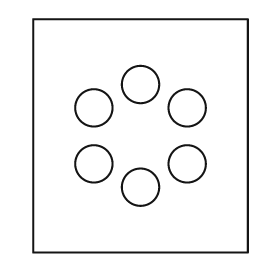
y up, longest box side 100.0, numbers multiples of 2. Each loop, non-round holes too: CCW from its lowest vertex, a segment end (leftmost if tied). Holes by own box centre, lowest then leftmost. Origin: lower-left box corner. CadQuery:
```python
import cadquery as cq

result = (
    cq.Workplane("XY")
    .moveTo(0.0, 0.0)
    .lineTo(92.0, 0.0)
    .lineTo(92.0, 100.0)
    .lineTo(0.0, 100.0)
    .close()
    .moveTo(46.0, 28.0)
    .circle(8.0)
    .moveTo(26.0, 38.0)
    .circle(8.0)
    .moveTo(66.0, 38.0)
    .circle(8.0)
    .moveTo(26.0, 62.0)
    .circle(8.0)
    .moveTo(66.0, 62.0)
    .circle(8.0)
    .moveTo(46.0, 72.0)
    .circle(8.0)
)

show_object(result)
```